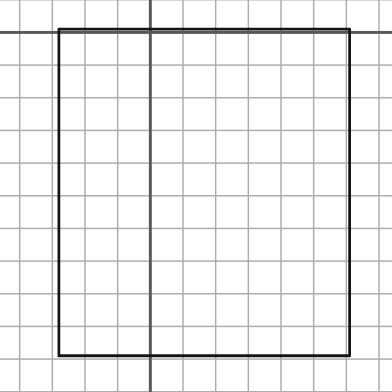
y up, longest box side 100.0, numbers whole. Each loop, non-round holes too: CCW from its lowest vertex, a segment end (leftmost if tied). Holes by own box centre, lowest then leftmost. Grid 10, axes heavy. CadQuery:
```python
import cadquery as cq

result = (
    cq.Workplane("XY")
    .moveTo(-28.0, -99.0)
    .lineTo(61.0, -99.0)
    .lineTo(61.0, 1.0)
    .lineTo(-28.0, 1.0)
    .close()
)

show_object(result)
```